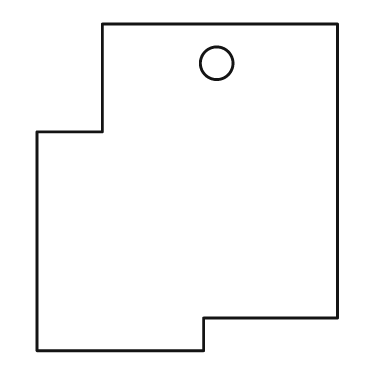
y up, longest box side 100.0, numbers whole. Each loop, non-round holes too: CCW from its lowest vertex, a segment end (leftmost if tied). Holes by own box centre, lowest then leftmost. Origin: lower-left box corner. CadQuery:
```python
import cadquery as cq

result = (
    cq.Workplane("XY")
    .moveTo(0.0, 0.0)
    .lineTo(51.0, 0.0)
    .lineTo(51.0, 10.0)
    .lineTo(92.0, 10.0)
    .lineTo(92.0, 100.0)
    .lineTo(20.0, 100.0)
    .lineTo(20.0, 67.0)
    .lineTo(0.0, 67.0)
    .close()
    .moveTo(55.0, 88.0)
    .circle(5.0)
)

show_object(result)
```